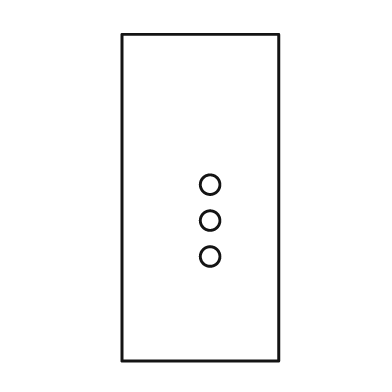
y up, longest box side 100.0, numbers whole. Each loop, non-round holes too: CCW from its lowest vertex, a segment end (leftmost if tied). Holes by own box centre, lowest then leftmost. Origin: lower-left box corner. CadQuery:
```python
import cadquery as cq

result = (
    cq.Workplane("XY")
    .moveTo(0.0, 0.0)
    .lineTo(48.0, 0.0)
    .lineTo(48.0, 100.0)
    .lineTo(0.0, 100.0)
    .close()
    .moveTo(27.0, 32.0)
    .circle(3.0)
    .moveTo(27.0, 43.0)
    .circle(3.0)
    .moveTo(27.0, 54.0)
    .circle(3.0)
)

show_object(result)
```